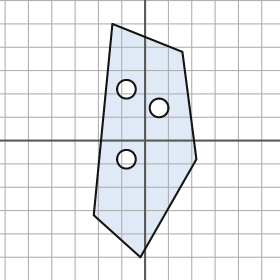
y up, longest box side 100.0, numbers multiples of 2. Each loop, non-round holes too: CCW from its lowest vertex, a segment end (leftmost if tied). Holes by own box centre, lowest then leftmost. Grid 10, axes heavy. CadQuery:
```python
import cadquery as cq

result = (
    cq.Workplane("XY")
    .moveTo(-2.0, -50.0)
    .lineTo(22.0, -8.0)
    .lineTo(16.0, 38.0)
    .lineTo(-14.0, 50.0)
    .lineTo(-22.0, -32.0)
    .close()
    .moveTo(-8.0, -8.0)
    .circle(4.0)
    .moveTo(6.0, 14.0)
    .circle(4.0)
    .moveTo(-8.0, 22.0)
    .circle(4.0)
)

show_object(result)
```